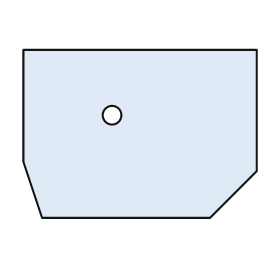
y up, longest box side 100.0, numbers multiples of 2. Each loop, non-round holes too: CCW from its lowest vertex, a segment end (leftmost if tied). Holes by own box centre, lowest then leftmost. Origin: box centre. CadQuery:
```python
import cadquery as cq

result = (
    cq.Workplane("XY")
    .moveTo(-42.0, -36.0)
    .lineTo(30.0, -36.0)
    .lineTo(50.0, -16.0)
    .lineTo(50.0, 36.0)
    .lineTo(-50.0, 36.0)
    .lineTo(-50.0, -12.0)
    .close()
    .moveTo(-12.0, 8.0)
    .circle(4.0)
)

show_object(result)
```